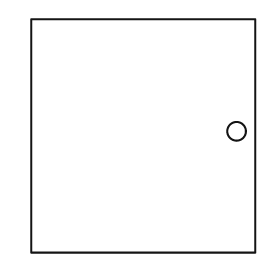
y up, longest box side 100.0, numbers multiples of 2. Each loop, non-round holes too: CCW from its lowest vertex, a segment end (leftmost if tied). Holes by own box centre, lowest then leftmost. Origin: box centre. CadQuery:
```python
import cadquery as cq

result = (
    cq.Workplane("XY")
    .moveTo(-48.0, -50.0)
    .lineTo(48.0, -50.0)
    .lineTo(48.0, 50.0)
    .lineTo(-48.0, 50.0)
    .close()
    .moveTo(40.0, 2.0)
    .circle(4.0)
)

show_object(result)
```